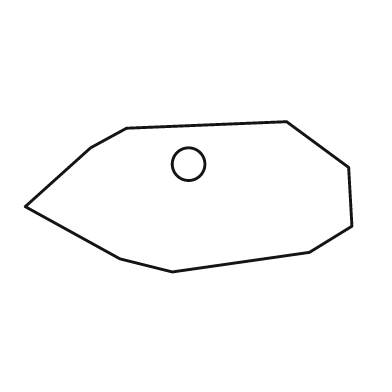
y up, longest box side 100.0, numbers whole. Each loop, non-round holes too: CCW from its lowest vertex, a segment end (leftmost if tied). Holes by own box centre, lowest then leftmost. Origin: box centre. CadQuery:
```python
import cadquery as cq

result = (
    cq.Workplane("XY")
    .moveTo(-5.0, -23.0)
    .lineTo(37.0, -17.0)
    .lineTo(50.0, -9.0)
    .lineTo(49.0, 9.0)
    .lineTo(30.0, 23.0)
    .lineTo(-19.0, 21.0)
    .lineTo(-30.0, 15.0)
    .lineTo(-50.0, -3.0)
    .lineTo(-21.0, -19.0)
    .close()
    .moveTo(0.0, 10.0)
    .circle(5.0)
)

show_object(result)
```